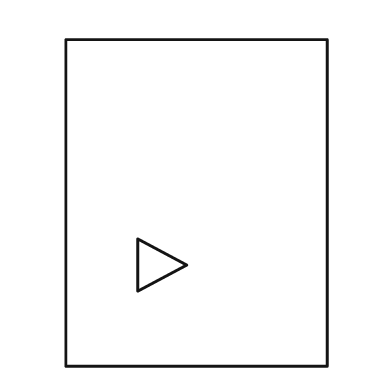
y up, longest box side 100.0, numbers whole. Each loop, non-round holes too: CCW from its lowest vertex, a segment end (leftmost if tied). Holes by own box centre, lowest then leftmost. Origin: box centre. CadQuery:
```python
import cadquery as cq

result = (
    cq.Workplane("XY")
    .moveTo(-40.0, -50.0)
    .lineTo(40.0, -50.0)
    .lineTo(40.0, 50.0)
    .lineTo(-40.0, 50.0)
    .close()
    .moveTo(-18.0, -27.0)
    .lineTo(-3.0, -19.0)
    .lineTo(-18.0, -11.0)
    .close()
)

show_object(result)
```